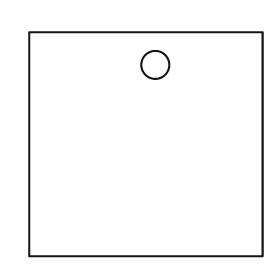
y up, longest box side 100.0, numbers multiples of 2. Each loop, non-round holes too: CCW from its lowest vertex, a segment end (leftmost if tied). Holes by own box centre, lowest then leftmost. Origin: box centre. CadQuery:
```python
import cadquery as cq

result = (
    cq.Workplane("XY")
    .moveTo(-50.0, -48.0)
    .lineTo(50.0, -48.0)
    .lineTo(50.0, 48.0)
    .lineTo(-50.0, 48.0)
    .close()
    .moveTo(4.0, 34.0)
    .circle(6.0)
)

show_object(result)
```